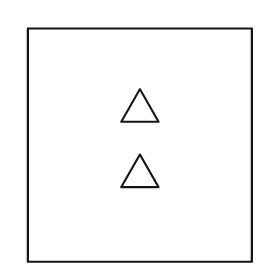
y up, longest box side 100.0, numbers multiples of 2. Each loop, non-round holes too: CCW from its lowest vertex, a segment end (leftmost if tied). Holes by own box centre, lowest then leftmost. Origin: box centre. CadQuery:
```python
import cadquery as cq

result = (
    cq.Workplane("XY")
    .moveTo(-48.0, -50.0)
    .lineTo(48.0, -50.0)
    .lineTo(48.0, 50.0)
    .lineTo(-48.0, 50.0)
    .close()
    .moveTo(-8.0, -18.0)
    .lineTo(8.0, -18.0)
    .lineTo(0.0, -4.0)
    .close()
    .moveTo(-8.0, 10.0)
    .lineTo(8.0, 10.0)
    .lineTo(0.0, 24.0)
    .close()
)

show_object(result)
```